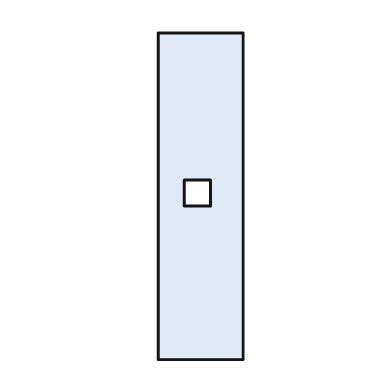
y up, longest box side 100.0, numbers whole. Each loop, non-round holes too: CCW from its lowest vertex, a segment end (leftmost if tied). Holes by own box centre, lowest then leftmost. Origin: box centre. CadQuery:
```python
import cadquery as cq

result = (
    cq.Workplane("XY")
    .moveTo(-13.0, -50.0)
    .lineTo(13.0, -50.0)
    .lineTo(13.0, 50.0)
    .lineTo(-13.0, 50.0)
    .close()
    .moveTo(-5.0, -3.0)
    .lineTo(3.0, -3.0)
    .lineTo(3.0, 5.0)
    .lineTo(-5.0, 5.0)
    .close()
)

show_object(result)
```